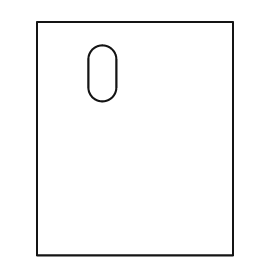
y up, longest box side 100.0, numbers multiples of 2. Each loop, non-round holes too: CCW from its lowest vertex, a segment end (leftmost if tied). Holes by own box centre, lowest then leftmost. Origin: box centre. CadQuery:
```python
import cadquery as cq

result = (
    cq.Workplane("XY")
    .moveTo(-42.0, -50.0)
    .lineTo(42.0, -50.0)
    .lineTo(42.0, 50.0)
    .lineTo(-42.0, 50.0)
    .close()
    .moveTo(-20.0, 22.0)
    .threePointArc((-14.0, 16.0), (-8.0, 22.0))
    .lineTo(-8.0, 34.0)
    .threePointArc((-14.0, 40.0), (-20.0, 34.0))
    .close()
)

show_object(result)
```